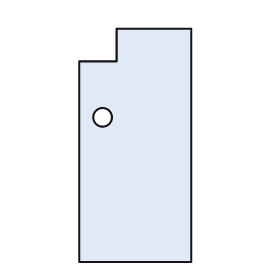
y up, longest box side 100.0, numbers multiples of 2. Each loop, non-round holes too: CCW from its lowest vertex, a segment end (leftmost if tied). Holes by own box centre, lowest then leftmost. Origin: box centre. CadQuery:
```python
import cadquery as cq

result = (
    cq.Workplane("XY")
    .moveTo(-24.0, -50.0)
    .lineTo(24.0, -50.0)
    .lineTo(24.0, 50.0)
    .lineTo(-8.0, 50.0)
    .lineTo(-8.0, 36.0)
    .lineTo(-24.0, 36.0)
    .close()
    .moveTo(-14.0, 12.0)
    .circle(4.0)
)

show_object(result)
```